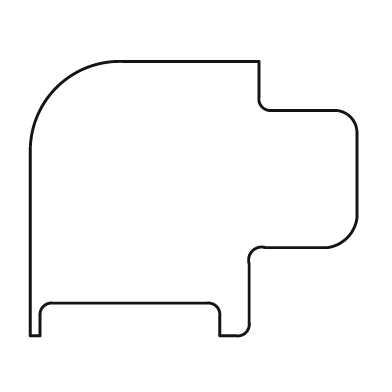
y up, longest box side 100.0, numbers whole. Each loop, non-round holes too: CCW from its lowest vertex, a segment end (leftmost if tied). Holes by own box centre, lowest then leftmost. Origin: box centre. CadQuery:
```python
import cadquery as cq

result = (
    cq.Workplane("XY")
    .moveTo(-50.0, -42.0)
    .lineTo(-47.0, -42.0)
    .lineTo(-47.0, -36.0)
    .threePointArc((-46.0, -33.0), (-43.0, -32.0))
    .lineTo(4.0, -32.0)
    .threePointArc((7.0, -33.0), (8.0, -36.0))
    .lineTo(8.0, -42.0)
    .lineTo(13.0, -42.0)
    .threePointArc((16.0, -41.0), (17.0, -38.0))
    .lineTo(17.0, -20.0)
    .threePointArc((18.0, -16.0), (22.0, -15.0))
    .lineTo(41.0, -15.0)
    .threePointArc((47.0, -12.0), (50.0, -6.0))
    .lineTo(50.0, 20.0)
    .threePointArc((48.0, 25.0), (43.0, 27.0))
    .lineTo(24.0, 27.0)
    .threePointArc((21.0, 28.0), (20.0, 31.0))
    .lineTo(20.0, 42.0)
    .lineTo(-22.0, 42.0)
    .threePointArc((-42.0, 34.0), (-50.0, 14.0))
    .close()
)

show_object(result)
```